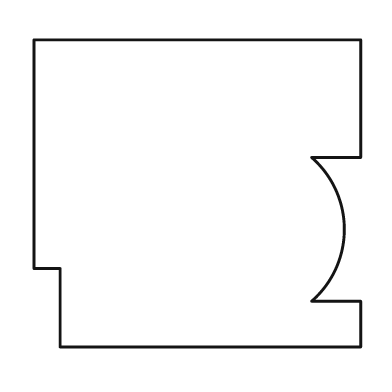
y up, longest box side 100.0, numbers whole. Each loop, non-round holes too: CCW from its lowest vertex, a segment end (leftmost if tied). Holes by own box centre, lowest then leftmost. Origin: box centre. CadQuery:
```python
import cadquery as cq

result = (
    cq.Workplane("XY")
    .moveTo(-42.0, -47.0)
    .lineTo(50.0, -47.0)
    .lineTo(50.0, -33.0)
    .lineTo(35.0, -33.0)
    .threePointArc((45.0, -11.0), (35.0, 11.0))
    .lineTo(50.0, 11.0)
    .lineTo(50.0, 47.0)
    .lineTo(-50.0, 47.0)
    .lineTo(-50.0, -23.0)
    .lineTo(-42.0, -23.0)
    .close()
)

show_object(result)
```